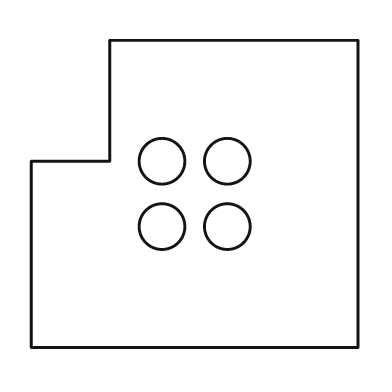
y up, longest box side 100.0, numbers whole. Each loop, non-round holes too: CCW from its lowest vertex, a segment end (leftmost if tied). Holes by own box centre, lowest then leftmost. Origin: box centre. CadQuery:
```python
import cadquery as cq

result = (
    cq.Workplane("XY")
    .moveTo(-50.0, -47.0)
    .lineTo(50.0, -47.0)
    .lineTo(50.0, 47.0)
    .lineTo(-26.0, 47.0)
    .lineTo(-26.0, 10.0)
    .lineTo(-50.0, 10.0)
    .close()
    .moveTo(-10.0, -10.0)
    .circle(7.0)
    .moveTo(10.0, -10.0)
    .circle(7.0)
    .moveTo(-10.0, 10.0)
    .circle(7.0)
    .moveTo(10.0, 10.0)
    .circle(7.0)
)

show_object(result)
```